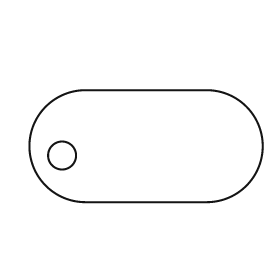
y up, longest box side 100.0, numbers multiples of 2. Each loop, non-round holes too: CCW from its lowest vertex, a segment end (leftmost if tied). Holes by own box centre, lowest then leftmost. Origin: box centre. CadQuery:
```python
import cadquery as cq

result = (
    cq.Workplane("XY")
    .moveTo(-26.0, -24.0)
    .lineTo(26.0, -24.0)
    .threePointArc((50.0, 0.0), (26.0, 24.0))
    .lineTo(-26.0, 24.0)
    .threePointArc((-50.0, 0.0), (-26.0, -24.0))
    .close()
    .moveTo(-36.0, -4.0)
    .circle(6.0)
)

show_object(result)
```